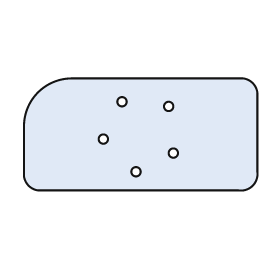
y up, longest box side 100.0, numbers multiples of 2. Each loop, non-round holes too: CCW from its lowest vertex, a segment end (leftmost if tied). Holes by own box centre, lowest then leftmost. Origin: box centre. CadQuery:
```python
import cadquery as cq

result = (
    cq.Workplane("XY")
    .moveTo(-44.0, -24.0)
    .lineTo(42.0, -24.0)
    .threePointArc((48.0, -22.0), (50.0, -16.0))
    .lineTo(50.0, 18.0)
    .threePointArc((48.0, 22.0), (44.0, 24.0))
    .lineTo(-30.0, 24.0)
    .threePointArc((-44.0, 18.0), (-50.0, 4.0))
    .lineTo(-50.0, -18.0)
    .threePointArc((-48.0, -22.0), (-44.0, -24.0))
    .close()
    .moveTo(-2.0, -16.0)
    .circle(2.0)
    .moveTo(14.0, -8.0)
    .circle(2.0)
    .moveTo(-16.0, -2.0)
    .circle(2.0)
    .moveTo(12.0, 12.0)
    .circle(2.0)
    .moveTo(-8.0, 14.0)
    .circle(2.0)
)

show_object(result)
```